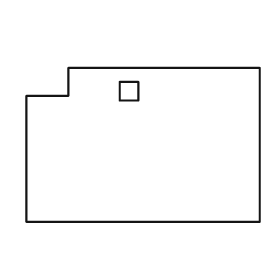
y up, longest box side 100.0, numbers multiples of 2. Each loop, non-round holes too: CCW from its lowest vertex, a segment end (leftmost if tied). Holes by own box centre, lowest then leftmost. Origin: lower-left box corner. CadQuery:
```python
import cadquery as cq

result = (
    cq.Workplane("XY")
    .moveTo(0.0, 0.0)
    .lineTo(100.0, 0.0)
    .lineTo(100.0, 66.0)
    .lineTo(18.0, 66.0)
    .lineTo(18.0, 54.0)
    .lineTo(0.0, 54.0)
    .close()
    .moveTo(40.0, 52.0)
    .lineTo(48.0, 52.0)
    .lineTo(48.0, 60.0)
    .lineTo(40.0, 60.0)
    .close()
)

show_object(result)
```